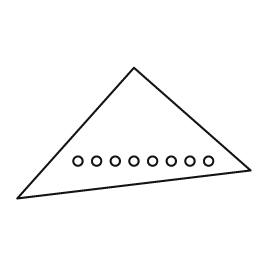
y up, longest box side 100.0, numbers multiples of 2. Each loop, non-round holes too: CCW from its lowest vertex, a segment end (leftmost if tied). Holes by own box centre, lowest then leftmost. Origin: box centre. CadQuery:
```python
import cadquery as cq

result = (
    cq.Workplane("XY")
    .moveTo(-50.0, -28.0)
    .lineTo(50.0, -16.0)
    .lineTo(0.0, 28.0)
    .close()
    .moveTo(-24.0, -12.0)
    .circle(2.0)
    .moveTo(-16.0, -12.0)
    .circle(2.0)
    .moveTo(-8.0, -12.0)
    .circle(2.0)
    .moveTo(0.0, -12.0)
    .circle(2.0)
    .moveTo(8.0, -12.0)
    .circle(2.0)
    .moveTo(16.0, -12.0)
    .circle(2.0)
    .moveTo(24.0, -12.0)
    .circle(2.0)
    .moveTo(32.0, -12.0)
    .circle(2.0)
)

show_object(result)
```